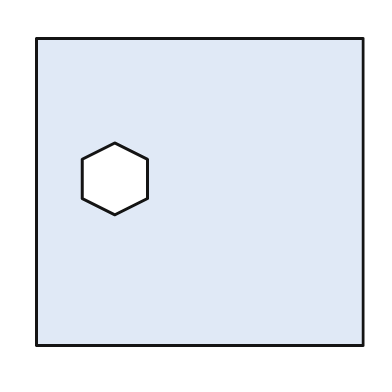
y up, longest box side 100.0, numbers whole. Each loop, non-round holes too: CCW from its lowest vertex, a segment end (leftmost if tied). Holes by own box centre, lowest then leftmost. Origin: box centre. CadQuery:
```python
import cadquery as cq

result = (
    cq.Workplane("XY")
    .moveTo(-50.0, -47.0)
    .lineTo(50.0, -47.0)
    .lineTo(50.0, 47.0)
    .lineTo(-50.0, 47.0)
    .close()
    .moveTo(-26.0, -7.0)
    .lineTo(-16.0, -2.0)
    .lineTo(-16.0, 10.0)
    .lineTo(-26.0, 15.0)
    .lineTo(-36.0, 10.0)
    .lineTo(-36.0, -2.0)
    .close()
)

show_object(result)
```